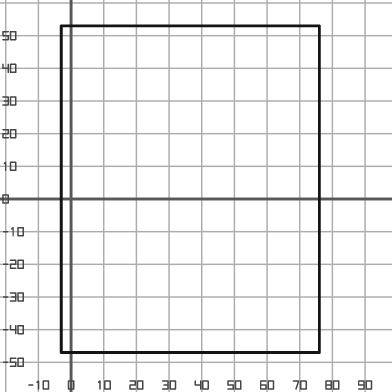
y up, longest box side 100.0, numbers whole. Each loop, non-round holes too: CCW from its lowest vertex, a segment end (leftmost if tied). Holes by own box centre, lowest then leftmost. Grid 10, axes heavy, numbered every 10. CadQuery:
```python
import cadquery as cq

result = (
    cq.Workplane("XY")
    .moveTo(-3.0, -47.0)
    .lineTo(76.0, -47.0)
    .lineTo(76.0, 53.0)
    .lineTo(-3.0, 53.0)
    .close()
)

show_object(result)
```